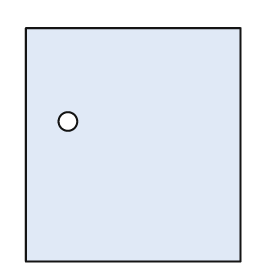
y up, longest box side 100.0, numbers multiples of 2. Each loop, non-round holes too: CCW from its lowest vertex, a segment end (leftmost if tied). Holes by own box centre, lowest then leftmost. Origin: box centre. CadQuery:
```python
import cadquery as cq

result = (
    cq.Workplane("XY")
    .moveTo(-46.0, -50.0)
    .lineTo(46.0, -50.0)
    .lineTo(46.0, 50.0)
    .lineTo(-46.0, 50.0)
    .close()
    .moveTo(-28.0, 10.0)
    .circle(4.0)
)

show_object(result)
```